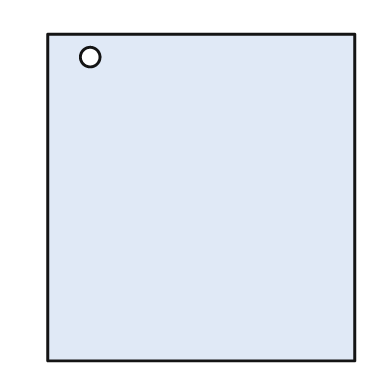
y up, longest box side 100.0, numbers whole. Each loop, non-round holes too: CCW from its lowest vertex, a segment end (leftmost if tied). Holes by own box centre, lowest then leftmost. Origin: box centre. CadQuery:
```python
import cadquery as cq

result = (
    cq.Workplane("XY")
    .moveTo(-47.0, -50.0)
    .lineTo(47.0, -50.0)
    .lineTo(47.0, 50.0)
    .lineTo(-47.0, 50.0)
    .close()
    .moveTo(-34.0, 43.0)
    .circle(3.0)
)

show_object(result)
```